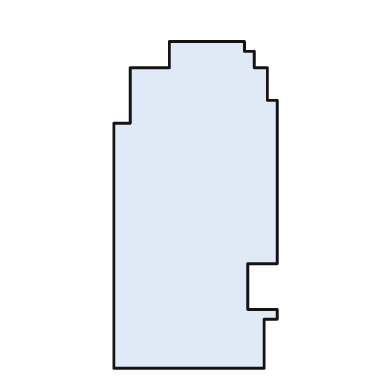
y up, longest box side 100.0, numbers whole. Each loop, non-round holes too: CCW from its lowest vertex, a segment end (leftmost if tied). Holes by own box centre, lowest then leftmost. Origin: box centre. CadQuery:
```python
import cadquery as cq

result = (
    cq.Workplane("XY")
    .moveTo(-25.0, -50.0)
    .lineTo(21.0, -50.0)
    .lineTo(21.0, -35.0)
    .lineTo(25.0, -35.0)
    .lineTo(25.0, -32.0)
    .lineTo(16.0, -32.0)
    .lineTo(16.0, -18.0)
    .lineTo(25.0, -18.0)
    .lineTo(25.0, 32.0)
    .lineTo(22.0, 32.0)
    .lineTo(22.0, 42.0)
    .lineTo(18.0, 42.0)
    .lineTo(18.0, 47.0)
    .lineTo(15.0, 47.0)
    .lineTo(15.0, 50.0)
    .lineTo(-8.0, 50.0)
    .lineTo(-8.0, 42.0)
    .lineTo(-20.0, 42.0)
    .lineTo(-20.0, 25.0)
    .lineTo(-25.0, 25.0)
    .close()
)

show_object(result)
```